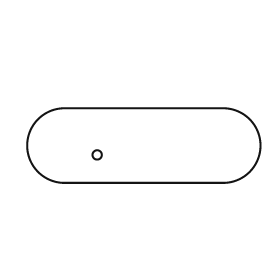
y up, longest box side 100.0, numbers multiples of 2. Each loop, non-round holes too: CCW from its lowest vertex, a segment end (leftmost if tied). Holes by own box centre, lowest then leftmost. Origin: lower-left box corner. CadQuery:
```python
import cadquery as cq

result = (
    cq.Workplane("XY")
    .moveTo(16.0, 0.0)
    .lineTo(84.0, 0.0)
    .threePointArc((100.0, 16.0), (84.0, 32.0))
    .lineTo(16.0, 32.0)
    .threePointArc((0.0, 16.0), (16.0, 0.0))
    .close()
    .moveTo(30.0, 12.0)
    .circle(2.0)
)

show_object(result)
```